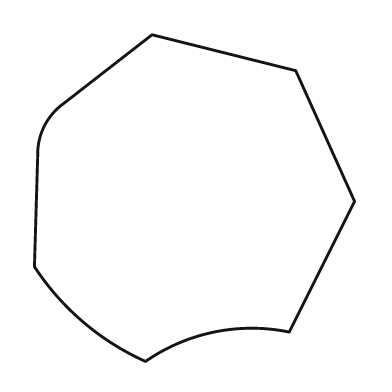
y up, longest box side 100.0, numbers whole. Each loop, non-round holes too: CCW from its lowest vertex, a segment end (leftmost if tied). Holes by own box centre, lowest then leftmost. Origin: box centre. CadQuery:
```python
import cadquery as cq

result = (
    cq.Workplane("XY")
    .moveTo(-15.0, -50.0)
    .threePointArc((6.0, -41.0), (29.0, -41.0))
    .lineTo(49.0, -1.0)
    .lineTo(31.0, 39.0)
    .lineTo(-13.0, 50.0)
    .lineTo(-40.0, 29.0)
    .threePointArc((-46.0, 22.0), (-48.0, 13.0))
    .lineTo(-49.0, -21.0)
    .threePointArc((-34.0, -38.0), (-15.0, -50.0))
    .close()
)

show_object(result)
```